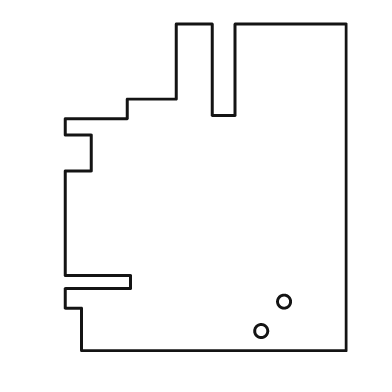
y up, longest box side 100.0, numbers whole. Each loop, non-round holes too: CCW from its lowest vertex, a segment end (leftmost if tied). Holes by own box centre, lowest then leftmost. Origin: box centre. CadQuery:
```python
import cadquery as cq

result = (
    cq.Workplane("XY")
    .moveTo(-38.0, -50.0)
    .lineTo(43.0, -50.0)
    .lineTo(43.0, 50.0)
    .lineTo(9.0, 50.0)
    .lineTo(9.0, 22.0)
    .lineTo(2.0, 22.0)
    .lineTo(2.0, 50.0)
    .lineTo(-9.0, 50.0)
    .lineTo(-9.0, 27.0)
    .lineTo(-24.0, 27.0)
    .lineTo(-24.0, 21.0)
    .lineTo(-43.0, 21.0)
    .lineTo(-43.0, 16.0)
    .lineTo(-35.0, 16.0)
    .lineTo(-35.0, 5.0)
    .lineTo(-43.0, 5.0)
    .lineTo(-43.0, -27.0)
    .lineTo(-23.0, -27.0)
    .lineTo(-23.0, -31.0)
    .lineTo(-43.0, -31.0)
    .lineTo(-43.0, -37.0)
    .lineTo(-38.0, -37.0)
    .close()
    .moveTo(17.0, -44.0)
    .circle(2.0)
    .moveTo(24.0, -35.0)
    .circle(2.0)
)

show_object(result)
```